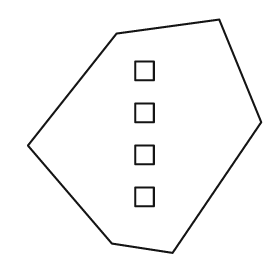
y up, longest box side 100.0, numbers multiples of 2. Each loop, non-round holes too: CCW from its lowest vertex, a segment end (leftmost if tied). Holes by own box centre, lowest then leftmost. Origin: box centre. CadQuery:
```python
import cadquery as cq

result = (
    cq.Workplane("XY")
    .moveTo(12.0, -50.0)
    .lineTo(50.0, 6.0)
    .lineTo(32.0, 50.0)
    .lineTo(-12.0, 44.0)
    .lineTo(-50.0, -4.0)
    .lineTo(-14.0, -46.0)
    .close()
    .moveTo(-4.0, -30.0)
    .lineTo(4.0, -30.0)
    .lineTo(4.0, -22.0)
    .lineTo(-4.0, -22.0)
    .close()
    .moveTo(-4.0, -12.0)
    .lineTo(4.0, -12.0)
    .lineTo(4.0, -4.0)
    .lineTo(-4.0, -4.0)
    .close()
    .moveTo(-4.0, 6.0)
    .lineTo(4.0, 6.0)
    .lineTo(4.0, 14.0)
    .lineTo(-4.0, 14.0)
    .close()
    .moveTo(-4.0, 24.0)
    .lineTo(4.0, 24.0)
    .lineTo(4.0, 32.0)
    .lineTo(-4.0, 32.0)
    .close()
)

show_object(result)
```